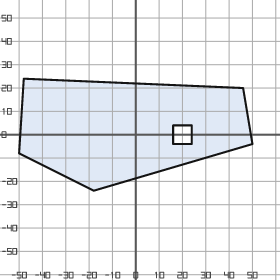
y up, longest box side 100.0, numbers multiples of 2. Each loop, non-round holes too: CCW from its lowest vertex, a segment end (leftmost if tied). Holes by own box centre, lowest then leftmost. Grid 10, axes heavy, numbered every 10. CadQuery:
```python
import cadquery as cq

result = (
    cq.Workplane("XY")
    .moveTo(-18.0, -24.0)
    .lineTo(50.0, -4.0)
    .lineTo(46.0, 20.0)
    .lineTo(-48.0, 24.0)
    .lineTo(-50.0, -8.0)
    .close()
    .moveTo(16.0, -4.0)
    .lineTo(24.0, -4.0)
    .lineTo(24.0, 4.0)
    .lineTo(16.0, 4.0)
    .close()
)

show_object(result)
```